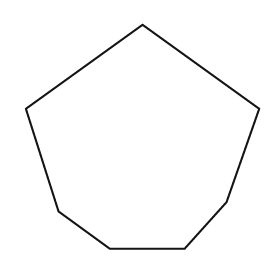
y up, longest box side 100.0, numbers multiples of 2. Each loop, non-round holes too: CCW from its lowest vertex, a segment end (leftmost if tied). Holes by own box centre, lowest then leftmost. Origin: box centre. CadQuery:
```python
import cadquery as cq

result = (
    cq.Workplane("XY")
    .moveTo(-14.0, -48.0)
    .lineTo(18.0, -48.0)
    .lineTo(36.0, -28.0)
    .lineTo(50.0, 12.0)
    .lineTo(0.0, 48.0)
    .lineTo(-50.0, 12.0)
    .lineTo(-36.0, -32.0)
    .close()
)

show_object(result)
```